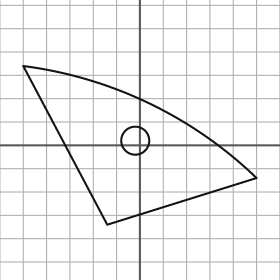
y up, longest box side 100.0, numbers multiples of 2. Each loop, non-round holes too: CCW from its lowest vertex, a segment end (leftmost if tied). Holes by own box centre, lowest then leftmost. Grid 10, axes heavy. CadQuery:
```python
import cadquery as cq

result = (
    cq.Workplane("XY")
    .moveTo(-14.0, -34.0)
    .lineTo(50.0, -14.0)
    .threePointArc((4.0, 18.0), (-50.0, 34.0))
    .close()
    .moveTo(-2.0, 2.0)
    .circle(6.0)
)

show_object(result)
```